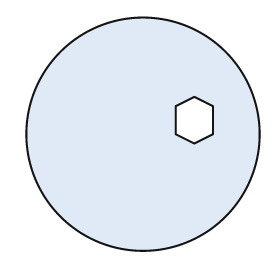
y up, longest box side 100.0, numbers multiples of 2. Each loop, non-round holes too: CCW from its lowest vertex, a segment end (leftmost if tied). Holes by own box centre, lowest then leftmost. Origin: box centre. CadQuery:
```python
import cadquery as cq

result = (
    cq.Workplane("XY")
    .moveTo(0.0, 0.0)
    .circle(50.0)
    .moveTo(22.0, -4.0)
    .lineTo(30.0, 0.0)
    .lineTo(30.0, 12.0)
    .lineTo(22.0, 16.0)
    .lineTo(14.0, 12.0)
    .lineTo(14.0, 0.0)
    .close()
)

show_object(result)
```